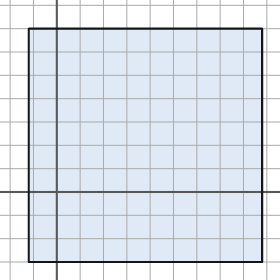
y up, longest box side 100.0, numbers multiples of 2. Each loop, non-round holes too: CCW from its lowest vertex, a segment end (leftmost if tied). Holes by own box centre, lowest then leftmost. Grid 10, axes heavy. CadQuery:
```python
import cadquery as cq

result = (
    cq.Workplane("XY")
    .moveTo(-12.0, -30.0)
    .lineTo(88.0, -30.0)
    .lineTo(88.0, 70.0)
    .lineTo(-12.0, 70.0)
    .close()
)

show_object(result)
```